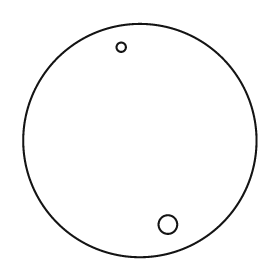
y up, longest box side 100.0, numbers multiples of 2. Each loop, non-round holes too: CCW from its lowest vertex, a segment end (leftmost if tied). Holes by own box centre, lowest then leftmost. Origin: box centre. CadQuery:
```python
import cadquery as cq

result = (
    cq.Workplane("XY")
    .moveTo(0.0, 0.0)
    .circle(50.0)
    .moveTo(12.0, -36.0)
    .circle(4.0)
    .moveTo(-8.0, 40.0)
    .circle(2.0)
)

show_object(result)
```